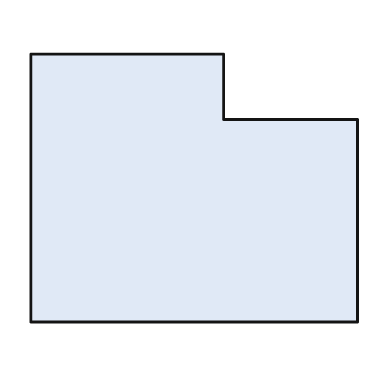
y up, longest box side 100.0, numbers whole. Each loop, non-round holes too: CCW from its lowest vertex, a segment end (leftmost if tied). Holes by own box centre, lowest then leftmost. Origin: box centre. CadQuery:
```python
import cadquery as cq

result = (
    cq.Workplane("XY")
    .moveTo(-50.0, -41.0)
    .lineTo(50.0, -41.0)
    .lineTo(50.0, 21.0)
    .lineTo(9.0, 21.0)
    .lineTo(9.0, 41.0)
    .lineTo(-50.0, 41.0)
    .close()
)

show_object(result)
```